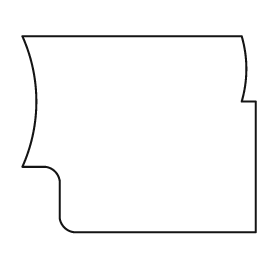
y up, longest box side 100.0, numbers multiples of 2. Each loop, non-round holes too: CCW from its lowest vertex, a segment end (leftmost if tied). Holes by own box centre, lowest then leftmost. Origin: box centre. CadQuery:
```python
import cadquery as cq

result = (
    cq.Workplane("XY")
    .moveTo(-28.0, -42.0)
    .lineTo(50.0, -42.0)
    .lineTo(50.0, 14.0)
    .lineTo(44.0, 14.0)
    .threePointArc((46.0, 28.0), (44.0, 42.0))
    .lineTo(-50.0, 42.0)
    .threePointArc((-44.0, 14.0), (-50.0, -14.0))
    .lineTo(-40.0, -14.0)
    .threePointArc((-36.0, -16.0), (-34.0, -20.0))
    .lineTo(-34.0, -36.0)
    .threePointArc((-32.0, -40.0), (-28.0, -42.0))
    .close()
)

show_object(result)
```